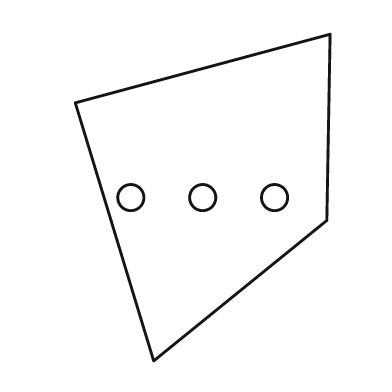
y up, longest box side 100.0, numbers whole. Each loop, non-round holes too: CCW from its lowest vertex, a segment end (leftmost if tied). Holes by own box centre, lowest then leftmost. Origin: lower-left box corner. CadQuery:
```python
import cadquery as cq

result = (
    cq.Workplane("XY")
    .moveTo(24.0, 0.0)
    .lineTo(77.0, 43.0)
    .lineTo(78.0, 100.0)
    .lineTo(0.0, 79.0)
    .close()
    .moveTo(17.0, 50.0)
    .circle(4.0)
    .moveTo(39.0, 50.0)
    .circle(4.0)
    .moveTo(61.0, 50.0)
    .circle(4.0)
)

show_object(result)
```